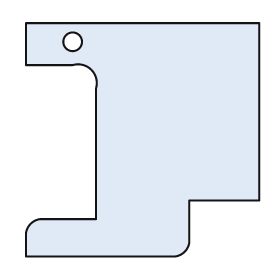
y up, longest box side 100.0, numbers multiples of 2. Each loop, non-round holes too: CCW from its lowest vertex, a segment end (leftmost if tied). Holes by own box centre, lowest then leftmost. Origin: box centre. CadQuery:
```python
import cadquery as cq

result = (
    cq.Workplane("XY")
    .moveTo(-50.0, -50.0)
    .lineTo(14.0, -50.0)
    .threePointArc((18.0, -48.0), (20.0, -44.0))
    .lineTo(20.0, -26.0)
    .lineTo(50.0, -26.0)
    .lineTo(50.0, 50.0)
    .lineTo(-50.0, 50.0)
    .lineTo(-50.0, 32.0)
    .lineTo(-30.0, 32.0)
    .threePointArc((-22.0, 30.0), (-20.0, 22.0))
    .lineTo(-20.0, -34.0)
    .lineTo(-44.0, -34.0)
    .threePointArc((-48.0, -36.0), (-50.0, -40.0))
    .close()
    .moveTo(-30.0, 42.0)
    .circle(4.0)
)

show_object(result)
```